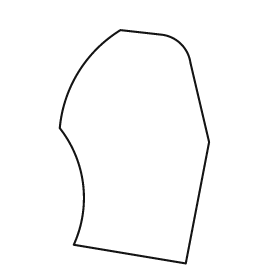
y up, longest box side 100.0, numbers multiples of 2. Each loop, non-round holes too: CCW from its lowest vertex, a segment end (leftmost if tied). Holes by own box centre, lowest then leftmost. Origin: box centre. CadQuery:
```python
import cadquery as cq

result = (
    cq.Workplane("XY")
    .moveTo(22.0, -50.0)
    .lineTo(32.0, 2.0)
    .lineTo(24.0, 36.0)
    .threePointArc((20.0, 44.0), (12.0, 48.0))
    .lineTo(-6.0, 50.0)
    .threePointArc((-24.0, 32.0), (-32.0, 8.0))
    .threePointArc((-22.0, -16.0), (-26.0, -42.0))
    .close()
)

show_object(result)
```